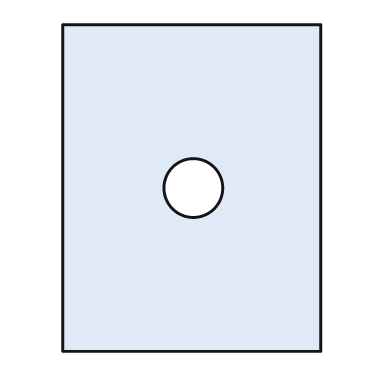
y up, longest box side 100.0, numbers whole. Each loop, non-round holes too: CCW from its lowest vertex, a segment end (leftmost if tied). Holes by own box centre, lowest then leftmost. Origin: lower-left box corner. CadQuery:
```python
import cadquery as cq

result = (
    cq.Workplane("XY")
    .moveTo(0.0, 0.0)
    .lineTo(79.0, 0.0)
    .lineTo(79.0, 100.0)
    .lineTo(0.0, 100.0)
    .close()
    .moveTo(40.0, 50.0)
    .circle(9.0)
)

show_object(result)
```